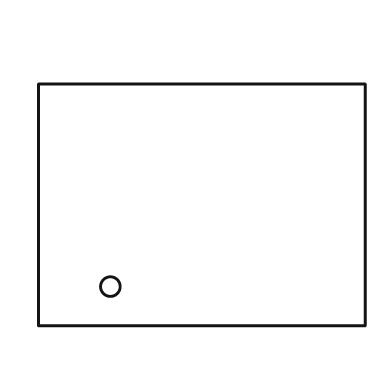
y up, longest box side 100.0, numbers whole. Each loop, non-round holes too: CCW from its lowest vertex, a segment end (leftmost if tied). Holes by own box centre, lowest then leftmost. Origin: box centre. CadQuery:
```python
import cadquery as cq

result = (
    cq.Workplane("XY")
    .moveTo(-50.0, -37.0)
    .lineTo(50.0, -37.0)
    .lineTo(50.0, 37.0)
    .lineTo(-50.0, 37.0)
    .close()
    .moveTo(-28.0, -25.0)
    .circle(3.0)
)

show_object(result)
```